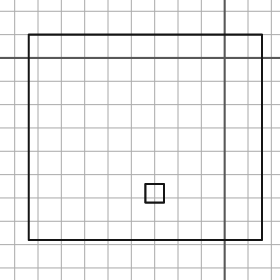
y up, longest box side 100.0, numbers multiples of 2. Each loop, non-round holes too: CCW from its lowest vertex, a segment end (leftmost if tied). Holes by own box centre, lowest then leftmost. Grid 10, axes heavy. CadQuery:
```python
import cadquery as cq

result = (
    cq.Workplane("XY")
    .moveTo(-84.0, -78.0)
    .lineTo(16.0, -78.0)
    .lineTo(16.0, 10.0)
    .lineTo(-84.0, 10.0)
    .close()
    .moveTo(-34.0, -62.0)
    .lineTo(-26.0, -62.0)
    .lineTo(-26.0, -54.0)
    .lineTo(-34.0, -54.0)
    .close()
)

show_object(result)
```